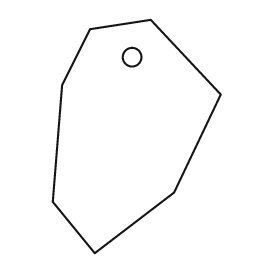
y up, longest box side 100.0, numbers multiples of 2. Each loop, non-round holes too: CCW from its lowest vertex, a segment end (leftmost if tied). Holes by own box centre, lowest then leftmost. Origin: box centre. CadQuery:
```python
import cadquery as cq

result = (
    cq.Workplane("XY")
    .moveTo(-18.0, -50.0)
    .lineTo(16.0, -24.0)
    .lineTo(36.0, 18.0)
    .lineTo(6.0, 50.0)
    .lineTo(-20.0, 46.0)
    .lineTo(-32.0, 22.0)
    .lineTo(-36.0, -28.0)
    .close()
    .moveTo(-2.0, 34.0)
    .circle(4.0)
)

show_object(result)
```